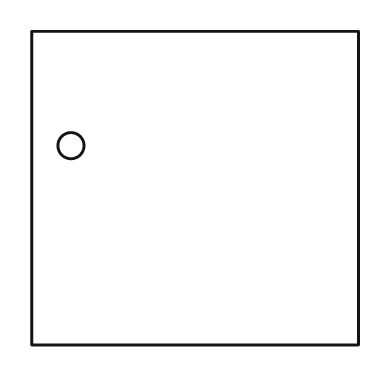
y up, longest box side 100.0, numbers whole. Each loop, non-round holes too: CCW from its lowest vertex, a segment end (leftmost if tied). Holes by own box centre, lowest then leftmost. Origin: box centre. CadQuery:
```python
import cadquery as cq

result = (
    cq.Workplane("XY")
    .moveTo(-50.0, -48.0)
    .lineTo(50.0, -48.0)
    .lineTo(50.0, 48.0)
    .lineTo(-50.0, 48.0)
    .close()
    .moveTo(-38.0, 13.0)
    .circle(4.0)
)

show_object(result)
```